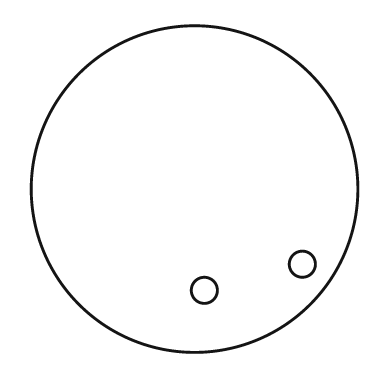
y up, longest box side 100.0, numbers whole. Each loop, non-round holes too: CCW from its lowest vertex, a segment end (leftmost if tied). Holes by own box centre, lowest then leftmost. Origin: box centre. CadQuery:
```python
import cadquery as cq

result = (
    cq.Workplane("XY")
    .moveTo(0.0, 0.0)
    .circle(50.0)
    .moveTo(3.0, -31.0)
    .circle(4.0)
    .moveTo(33.0, -23.0)
    .circle(4.0)
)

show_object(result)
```